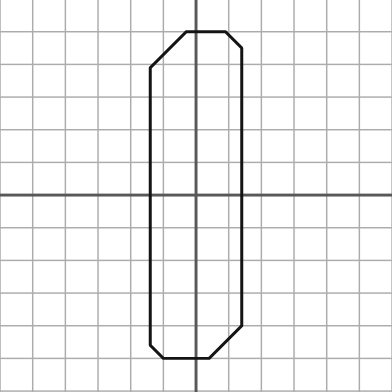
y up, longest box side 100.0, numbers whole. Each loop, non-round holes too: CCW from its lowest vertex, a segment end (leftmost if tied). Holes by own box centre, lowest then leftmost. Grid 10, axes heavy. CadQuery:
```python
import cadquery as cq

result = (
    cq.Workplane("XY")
    .moveTo(-10.0, -50.0)
    .lineTo(4.0, -50.0)
    .lineTo(14.0, -40.0)
    .lineTo(14.0, 45.0)
    .lineTo(9.0, 50.0)
    .lineTo(-3.0, 50.0)
    .lineTo(-14.0, 39.0)
    .lineTo(-14.0, -46.0)
    .close()
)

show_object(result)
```